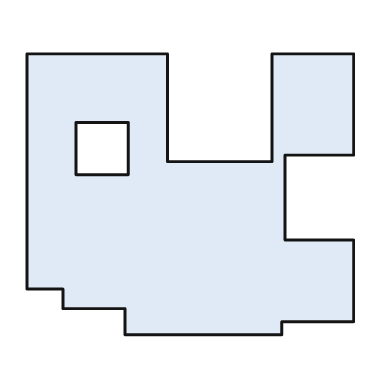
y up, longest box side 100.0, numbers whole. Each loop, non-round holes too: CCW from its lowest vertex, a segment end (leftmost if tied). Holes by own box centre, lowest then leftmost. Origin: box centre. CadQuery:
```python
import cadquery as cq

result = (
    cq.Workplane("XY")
    .moveTo(-20.0, -43.0)
    .lineTo(28.0, -43.0)
    .lineTo(28.0, -39.0)
    .lineTo(50.0, -39.0)
    .lineTo(50.0, -14.0)
    .lineTo(29.0, -14.0)
    .lineTo(29.0, 12.0)
    .lineTo(50.0, 12.0)
    .lineTo(50.0, 43.0)
    .lineTo(25.0, 43.0)
    .lineTo(25.0, 10.0)
    .lineTo(-7.0, 10.0)
    .lineTo(-7.0, 43.0)
    .lineTo(-50.0, 43.0)
    .lineTo(-50.0, -29.0)
    .lineTo(-39.0, -29.0)
    .lineTo(-39.0, -35.0)
    .lineTo(-20.0, -35.0)
    .close()
    .moveTo(-35.0, 6.0)
    .lineTo(-19.0, 6.0)
    .lineTo(-19.0, 22.0)
    .lineTo(-35.0, 22.0)
    .close()
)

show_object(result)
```